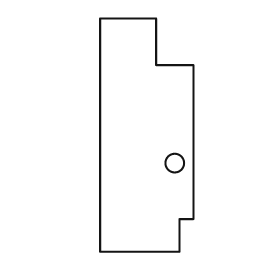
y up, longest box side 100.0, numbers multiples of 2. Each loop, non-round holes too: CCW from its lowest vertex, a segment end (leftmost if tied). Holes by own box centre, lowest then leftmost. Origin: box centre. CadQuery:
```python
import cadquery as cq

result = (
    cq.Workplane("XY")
    .moveTo(-20.0, -50.0)
    .lineTo(14.0, -50.0)
    .lineTo(14.0, -36.0)
    .lineTo(20.0, -36.0)
    .lineTo(20.0, 30.0)
    .lineTo(4.0, 30.0)
    .lineTo(4.0, 50.0)
    .lineTo(-20.0, 50.0)
    .close()
    .moveTo(12.0, -12.0)
    .circle(4.0)
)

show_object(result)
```